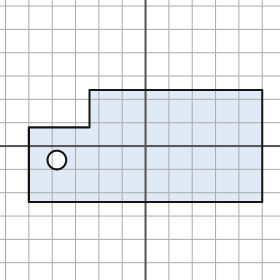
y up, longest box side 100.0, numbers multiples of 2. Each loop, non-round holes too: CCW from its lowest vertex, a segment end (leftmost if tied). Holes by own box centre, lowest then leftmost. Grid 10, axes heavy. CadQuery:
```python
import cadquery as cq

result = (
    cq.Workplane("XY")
    .moveTo(-50.0, -24.0)
    .lineTo(50.0, -24.0)
    .lineTo(50.0, 24.0)
    .lineTo(-24.0, 24.0)
    .lineTo(-24.0, 8.0)
    .lineTo(-50.0, 8.0)
    .close()
    .moveTo(-38.0, -6.0)
    .circle(4.0)
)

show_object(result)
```